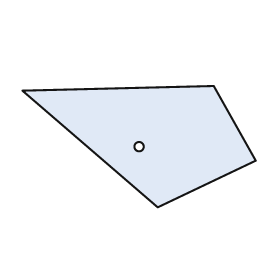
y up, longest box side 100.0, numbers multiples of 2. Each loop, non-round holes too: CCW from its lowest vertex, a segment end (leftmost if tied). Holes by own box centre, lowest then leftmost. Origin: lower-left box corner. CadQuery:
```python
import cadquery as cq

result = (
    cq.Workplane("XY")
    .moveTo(58.0, 0.0)
    .lineTo(100.0, 20.0)
    .lineTo(82.0, 52.0)
    .lineTo(0.0, 50.0)
    .close()
    .moveTo(50.0, 26.0)
    .circle(2.0)
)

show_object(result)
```